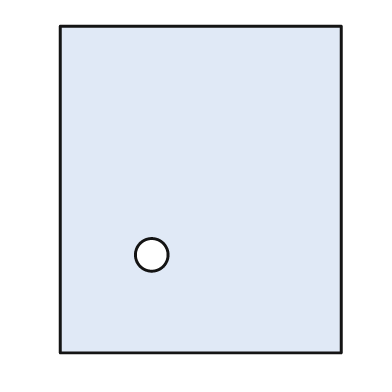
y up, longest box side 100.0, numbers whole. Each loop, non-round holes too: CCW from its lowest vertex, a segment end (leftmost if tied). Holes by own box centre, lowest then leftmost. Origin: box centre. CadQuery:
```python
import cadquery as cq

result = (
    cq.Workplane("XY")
    .moveTo(-43.0, -50.0)
    .lineTo(43.0, -50.0)
    .lineTo(43.0, 50.0)
    .lineTo(-43.0, 50.0)
    .close()
    .moveTo(-15.0, -20.0)
    .circle(5.0)
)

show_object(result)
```